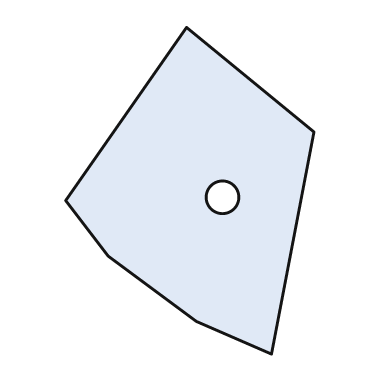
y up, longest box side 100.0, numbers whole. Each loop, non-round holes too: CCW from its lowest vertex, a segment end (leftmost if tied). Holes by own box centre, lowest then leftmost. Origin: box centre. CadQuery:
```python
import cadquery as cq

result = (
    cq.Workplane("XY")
    .moveTo(25.0, -50.0)
    .lineTo(38.0, 18.0)
    .lineTo(-1.0, 50.0)
    .lineTo(-38.0, -3.0)
    .lineTo(-25.0, -20.0)
    .lineTo(2.0, -40.0)
    .close()
    .moveTo(10.0, -2.0)
    .circle(5.0)
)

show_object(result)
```